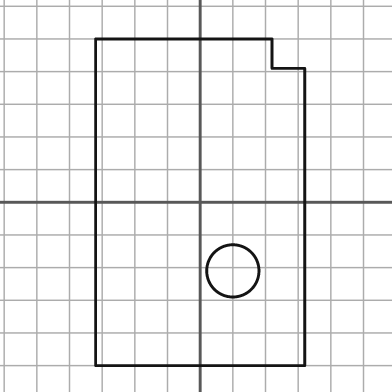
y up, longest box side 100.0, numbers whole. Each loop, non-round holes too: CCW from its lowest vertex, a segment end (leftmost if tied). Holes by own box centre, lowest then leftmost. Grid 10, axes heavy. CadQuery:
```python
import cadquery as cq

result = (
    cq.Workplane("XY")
    .moveTo(-32.0, -50.0)
    .lineTo(32.0, -50.0)
    .lineTo(32.0, 41.0)
    .lineTo(22.0, 41.0)
    .lineTo(22.0, 50.0)
    .lineTo(-32.0, 50.0)
    .close()
    .moveTo(10.0, -21.0)
    .circle(8.0)
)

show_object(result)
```